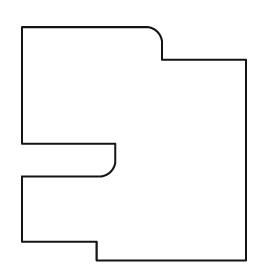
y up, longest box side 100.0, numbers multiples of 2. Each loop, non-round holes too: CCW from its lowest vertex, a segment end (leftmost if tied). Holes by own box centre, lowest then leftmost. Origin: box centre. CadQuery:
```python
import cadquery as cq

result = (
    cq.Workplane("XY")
    .moveTo(-16.0, -50.0)
    .lineTo(48.0, -50.0)
    .lineTo(48.0, 36.0)
    .lineTo(12.0, 36.0)
    .lineTo(12.0, 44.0)
    .threePointArc((10.0, 48.0), (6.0, 50.0))
    .lineTo(-48.0, 50.0)
    .lineTo(-48.0, 0.0)
    .lineTo(-8.0, 0.0)
    .lineTo(-8.0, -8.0)
    .threePointArc((-10.0, -12.0), (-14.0, -14.0))
    .lineTo(-48.0, -14.0)
    .lineTo(-48.0, -42.0)
    .lineTo(-16.0, -42.0)
    .close()
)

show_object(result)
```